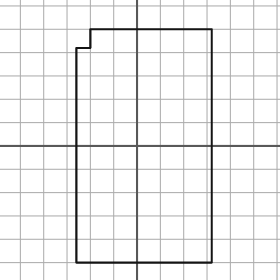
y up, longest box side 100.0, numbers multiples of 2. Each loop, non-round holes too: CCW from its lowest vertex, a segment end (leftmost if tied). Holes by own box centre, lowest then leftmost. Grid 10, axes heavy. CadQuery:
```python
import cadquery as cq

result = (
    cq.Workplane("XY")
    .moveTo(-26.0, -50.0)
    .lineTo(32.0, -50.0)
    .lineTo(32.0, 50.0)
    .lineTo(-20.0, 50.0)
    .lineTo(-20.0, 42.0)
    .lineTo(-26.0, 42.0)
    .close()
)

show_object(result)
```